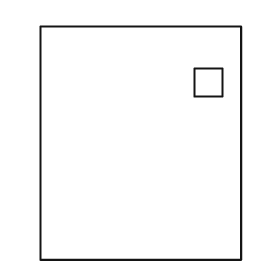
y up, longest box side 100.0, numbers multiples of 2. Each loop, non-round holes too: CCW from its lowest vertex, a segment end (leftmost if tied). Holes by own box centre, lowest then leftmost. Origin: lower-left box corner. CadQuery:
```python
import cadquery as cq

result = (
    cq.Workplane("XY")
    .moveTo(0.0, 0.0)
    .lineTo(86.0, 0.0)
    .lineTo(86.0, 100.0)
    .lineTo(0.0, 100.0)
    .close()
    .moveTo(66.0, 70.0)
    .lineTo(78.0, 70.0)
    .lineTo(78.0, 82.0)
    .lineTo(66.0, 82.0)
    .close()
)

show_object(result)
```